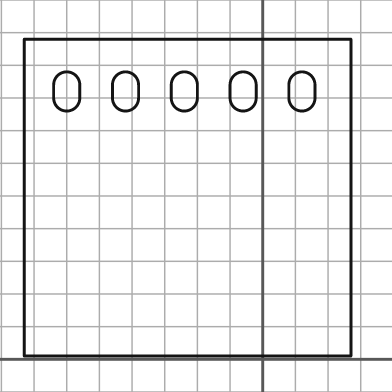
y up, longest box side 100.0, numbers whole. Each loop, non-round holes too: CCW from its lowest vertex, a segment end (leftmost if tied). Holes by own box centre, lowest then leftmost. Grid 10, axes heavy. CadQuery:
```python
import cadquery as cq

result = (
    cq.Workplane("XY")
    .moveTo(-73.0, 1.0)
    .lineTo(27.0, 1.0)
    .lineTo(27.0, 98.0)
    .lineTo(-73.0, 98.0)
    .close()
    .moveTo(-64.0, 80.0)
    .threePointArc((-60.0, 76.0), (-56.0, 80.0))
    .lineTo(-56.0, 84.0)
    .threePointArc((-60.0, 88.0), (-64.0, 84.0))
    .close()
    .moveTo(-46.0, 80.0)
    .threePointArc((-42.0, 76.0), (-38.0, 80.0))
    .lineTo(-38.0, 84.0)
    .threePointArc((-42.0, 88.0), (-46.0, 84.0))
    .close()
    .moveTo(-28.0, 80.0)
    .threePointArc((-24.0, 76.0), (-20.0, 80.0))
    .lineTo(-20.0, 84.0)
    .threePointArc((-24.0, 88.0), (-28.0, 84.0))
    .close()
    .moveTo(-10.0, 80.0)
    .threePointArc((-6.0, 76.0), (-2.0, 80.0))
    .lineTo(-2.0, 84.0)
    .threePointArc((-6.0, 88.0), (-10.0, 84.0))
    .close()
    .moveTo(8.0, 80.0)
    .threePointArc((12.0, 76.0), (16.0, 80.0))
    .lineTo(16.0, 84.0)
    .threePointArc((12.0, 88.0), (8.0, 84.0))
    .close()
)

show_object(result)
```